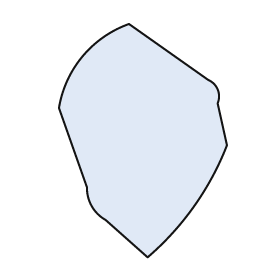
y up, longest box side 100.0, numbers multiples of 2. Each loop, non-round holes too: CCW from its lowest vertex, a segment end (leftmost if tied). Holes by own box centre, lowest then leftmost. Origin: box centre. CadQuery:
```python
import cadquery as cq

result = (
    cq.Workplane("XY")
    .moveTo(2.0, -50.0)
    .threePointArc((22.0, -28.0), (36.0, -2.0))
    .lineTo(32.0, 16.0)
    .threePointArc((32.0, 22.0), (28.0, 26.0))
    .lineTo(-6.0, 50.0)
    .threePointArc((-26.0, 36.0), (-36.0, 14.0))
    .lineTo(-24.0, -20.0)
    .threePointArc((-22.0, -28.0), (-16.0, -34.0))
    .close()
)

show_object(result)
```